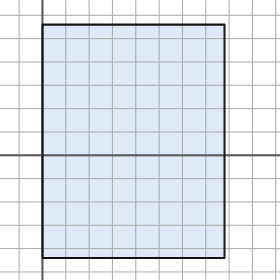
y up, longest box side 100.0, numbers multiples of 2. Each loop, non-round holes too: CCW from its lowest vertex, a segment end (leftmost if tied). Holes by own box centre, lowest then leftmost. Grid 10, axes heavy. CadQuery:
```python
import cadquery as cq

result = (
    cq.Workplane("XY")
    .moveTo(0.0, -44.0)
    .lineTo(78.0, -44.0)
    .lineTo(78.0, 56.0)
    .lineTo(0.0, 56.0)
    .close()
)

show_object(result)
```